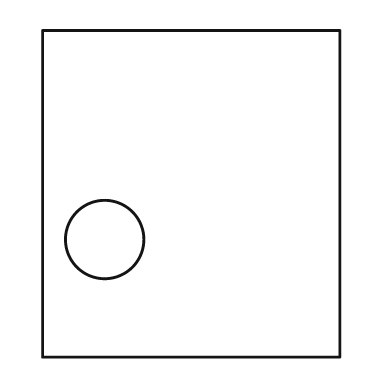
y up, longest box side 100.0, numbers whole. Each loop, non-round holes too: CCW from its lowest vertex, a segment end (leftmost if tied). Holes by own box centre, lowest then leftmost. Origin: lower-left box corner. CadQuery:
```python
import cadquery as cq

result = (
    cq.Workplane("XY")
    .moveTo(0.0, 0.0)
    .lineTo(91.0, 0.0)
    .lineTo(91.0, 100.0)
    .lineTo(0.0, 100.0)
    .close()
    .moveTo(19.0, 36.0)
    .circle(12.0)
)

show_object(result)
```